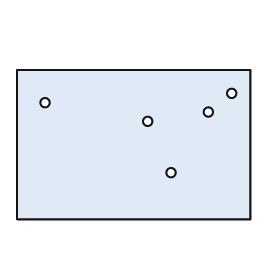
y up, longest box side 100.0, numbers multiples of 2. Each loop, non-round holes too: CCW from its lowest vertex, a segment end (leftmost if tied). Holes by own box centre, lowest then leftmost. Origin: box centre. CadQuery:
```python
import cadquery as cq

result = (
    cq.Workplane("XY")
    .moveTo(-50.0, -32.0)
    .lineTo(50.0, -32.0)
    .lineTo(50.0, 32.0)
    .lineTo(-50.0, 32.0)
    .close()
    .moveTo(16.0, -12.0)
    .circle(2.0)
    .moveTo(6.0, 10.0)
    .circle(2.0)
    .moveTo(32.0, 14.0)
    .circle(2.0)
    .moveTo(-38.0, 18.0)
    .circle(2.0)
    .moveTo(42.0, 22.0)
    .circle(2.0)
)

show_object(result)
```